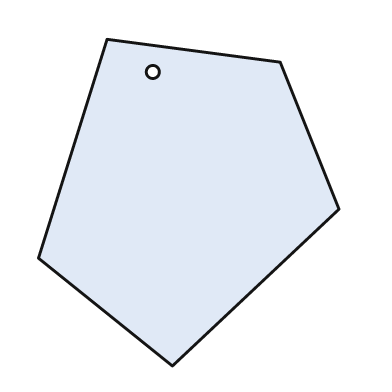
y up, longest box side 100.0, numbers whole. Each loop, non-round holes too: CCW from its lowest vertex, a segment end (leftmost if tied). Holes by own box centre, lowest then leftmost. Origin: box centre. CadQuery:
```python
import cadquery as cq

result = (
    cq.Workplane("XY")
    .moveTo(-5.0, -50.0)
    .lineTo(46.0, -2.0)
    .lineTo(28.0, 43.0)
    .lineTo(-25.0, 50.0)
    .lineTo(-46.0, -17.0)
    .close()
    .moveTo(-11.0, 40.0)
    .circle(2.0)
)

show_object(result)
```